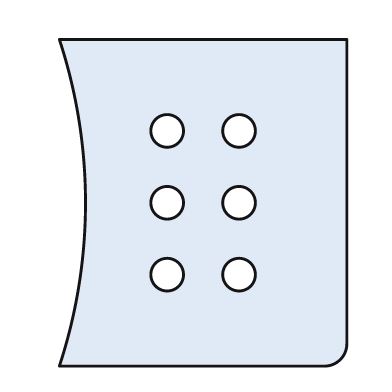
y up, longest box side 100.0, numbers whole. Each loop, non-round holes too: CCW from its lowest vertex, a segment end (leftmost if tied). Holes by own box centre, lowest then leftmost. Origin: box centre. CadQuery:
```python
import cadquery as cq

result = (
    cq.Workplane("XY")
    .moveTo(-44.0, -50.0)
    .lineTo(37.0, -50.0)
    .threePointArc((42.0, -48.0), (44.0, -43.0))
    .lineTo(44.0, 50.0)
    .lineTo(-44.0, 50.0)
    .threePointArc((-36.0, 0.0), (-44.0, -50.0))
    .close()
    .moveTo(-11.0, -22.0)
    .circle(5.0)
    .moveTo(11.0, -22.0)
    .circle(5.0)
    .moveTo(-11.0, 0.0)
    .circle(5.0)
    .moveTo(11.0, 0.0)
    .circle(5.0)
    .moveTo(-11.0, 22.0)
    .circle(5.0)
    .moveTo(11.0, 22.0)
    .circle(5.0)
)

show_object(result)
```